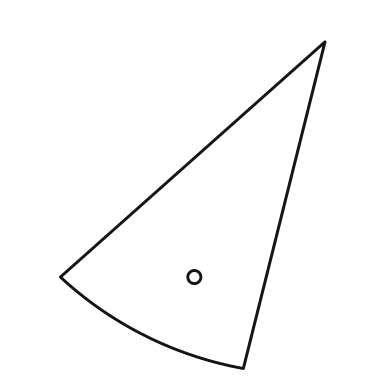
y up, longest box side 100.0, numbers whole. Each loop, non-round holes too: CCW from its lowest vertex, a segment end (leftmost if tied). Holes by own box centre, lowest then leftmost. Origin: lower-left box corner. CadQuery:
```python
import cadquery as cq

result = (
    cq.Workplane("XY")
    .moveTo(56.0, 0.0)
    .lineTo(81.0, 100.0)
    .lineTo(0.0, 28.0)
    .threePointArc((26.0, 10.0), (56.0, 0.0))
    .close()
    .moveTo(41.0, 28.0)
    .circle(2.0)
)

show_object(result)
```